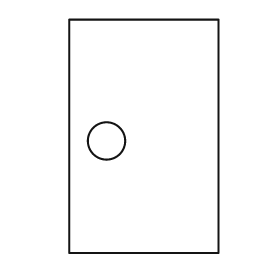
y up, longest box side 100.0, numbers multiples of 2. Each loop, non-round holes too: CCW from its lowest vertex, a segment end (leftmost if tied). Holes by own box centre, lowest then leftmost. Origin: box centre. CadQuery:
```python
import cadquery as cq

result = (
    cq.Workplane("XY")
    .moveTo(-32.0, -50.0)
    .lineTo(32.0, -50.0)
    .lineTo(32.0, 50.0)
    .lineTo(-32.0, 50.0)
    .close()
    .moveTo(-16.0, -2.0)
    .circle(8.0)
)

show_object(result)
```